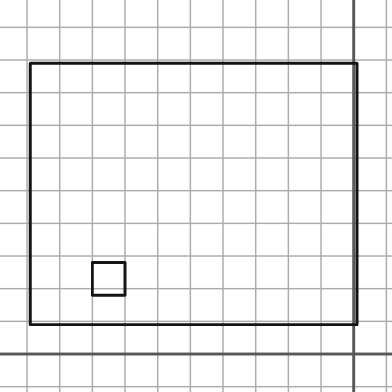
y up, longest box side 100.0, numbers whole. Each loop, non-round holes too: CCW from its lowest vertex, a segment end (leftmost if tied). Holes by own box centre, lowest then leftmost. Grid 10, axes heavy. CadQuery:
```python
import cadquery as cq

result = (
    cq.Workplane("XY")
    .moveTo(-99.0, 9.0)
    .lineTo(1.0, 9.0)
    .lineTo(1.0, 89.0)
    .lineTo(-99.0, 89.0)
    .close()
    .moveTo(-80.0, 18.0)
    .lineTo(-70.0, 18.0)
    .lineTo(-70.0, 28.0)
    .lineTo(-80.0, 28.0)
    .close()
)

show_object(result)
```